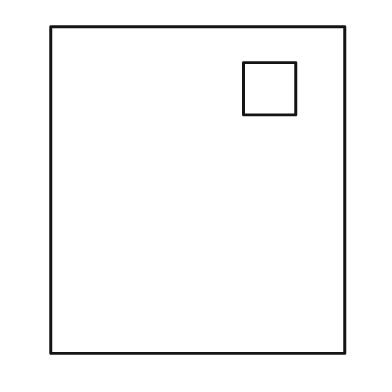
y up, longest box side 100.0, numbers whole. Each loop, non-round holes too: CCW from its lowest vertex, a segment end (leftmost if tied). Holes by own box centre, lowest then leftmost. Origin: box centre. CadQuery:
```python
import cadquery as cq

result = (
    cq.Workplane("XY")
    .moveTo(-45.0, -50.0)
    .lineTo(45.0, -50.0)
    .lineTo(45.0, 50.0)
    .lineTo(-45.0, 50.0)
    .close()
    .moveTo(14.0, 23.0)
    .lineTo(30.0, 23.0)
    .lineTo(30.0, 39.0)
    .lineTo(14.0, 39.0)
    .close()
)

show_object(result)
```